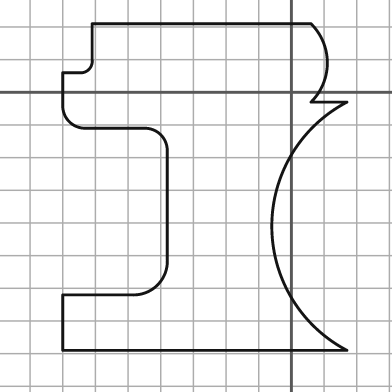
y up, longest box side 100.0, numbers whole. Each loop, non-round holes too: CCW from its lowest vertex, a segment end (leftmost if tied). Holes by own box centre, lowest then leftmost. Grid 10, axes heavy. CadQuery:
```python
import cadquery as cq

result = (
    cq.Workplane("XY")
    .moveTo(-70.0, -79.0)
    .lineTo(17.0, -79.0)
    .threePointArc((-6.0, -41.0), (17.0, -3.0))
    .lineTo(6.0, -3.0)
    .threePointArc((11.0, 9.0), (6.0, 21.0))
    .lineTo(-61.0, 21.0)
    .lineTo(-61.0, 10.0)
    .threePointArc((-62.0, 7.0), (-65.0, 6.0))
    .lineTo(-70.0, 6.0)
    .lineTo(-70.0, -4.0)
    .threePointArc((-68.0, -9.0), (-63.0, -11.0))
    .lineTo(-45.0, -11.0)
    .threePointArc((-40.0, -13.0), (-38.0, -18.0))
    .lineTo(-38.0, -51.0)
    .threePointArc((-41.0, -59.0), (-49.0, -62.0))
    .lineTo(-70.0, -62.0)
    .close()
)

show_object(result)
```